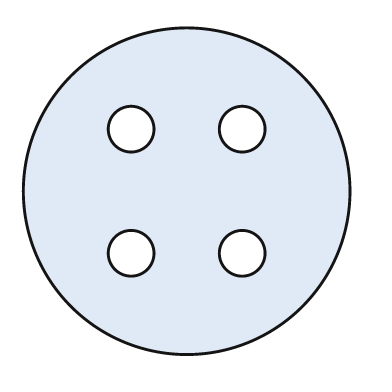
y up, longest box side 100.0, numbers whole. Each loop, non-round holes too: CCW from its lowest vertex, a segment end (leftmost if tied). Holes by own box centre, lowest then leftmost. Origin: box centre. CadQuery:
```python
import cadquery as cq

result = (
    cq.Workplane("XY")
    .moveTo(0.0, 0.0)
    .circle(50.0)
    .moveTo(-17.0, -19.0)
    .circle(7.0)
    .moveTo(17.0, -19.0)
    .circle(7.0)
    .moveTo(-17.0, 19.0)
    .circle(7.0)
    .moveTo(17.0, 19.0)
    .circle(7.0)
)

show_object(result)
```